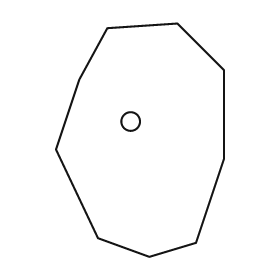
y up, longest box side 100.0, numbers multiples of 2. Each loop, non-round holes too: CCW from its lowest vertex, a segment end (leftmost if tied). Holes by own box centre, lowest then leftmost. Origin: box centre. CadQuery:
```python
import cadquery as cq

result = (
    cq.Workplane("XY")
    .moveTo(4.0, -50.0)
    .lineTo(24.0, -44.0)
    .lineTo(36.0, -8.0)
    .lineTo(36.0, 30.0)
    .lineTo(16.0, 50.0)
    .lineTo(-14.0, 48.0)
    .lineTo(-26.0, 26.0)
    .lineTo(-36.0, -4.0)
    .lineTo(-18.0, -42.0)
    .close()
    .moveTo(-4.0, 8.0)
    .circle(4.0)
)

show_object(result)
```